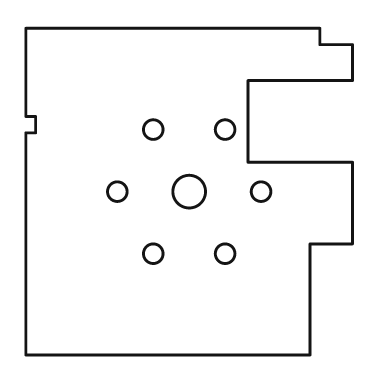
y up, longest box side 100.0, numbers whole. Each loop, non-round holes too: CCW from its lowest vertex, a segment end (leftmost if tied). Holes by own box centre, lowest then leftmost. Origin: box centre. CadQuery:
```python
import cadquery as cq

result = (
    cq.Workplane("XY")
    .moveTo(-50.0, -50.0)
    .lineTo(37.0, -50.0)
    .lineTo(37.0, -16.0)
    .lineTo(50.0, -16.0)
    .lineTo(50.0, 9.0)
    .lineTo(18.0, 9.0)
    .lineTo(18.0, 34.0)
    .lineTo(50.0, 34.0)
    .lineTo(50.0, 45.0)
    .lineTo(40.0, 45.0)
    .lineTo(40.0, 50.0)
    .lineTo(-50.0, 50.0)
    .lineTo(-50.0, 23.0)
    .lineTo(-47.0, 23.0)
    .lineTo(-47.0, 18.0)
    .lineTo(-50.0, 18.0)
    .close()
    .moveTo(-11.0, -19.0)
    .circle(3.0)
    .moveTo(11.0, -19.0)
    .circle(3.0)
    .moveTo(-22.0, 0.0)
    .circle(3.0)
    .moveTo(0.0, 0.0)
    .circle(5.0)
    .moveTo(22.0, 0.0)
    .circle(3.0)
    .moveTo(-11.0, 19.0)
    .circle(3.0)
    .moveTo(11.0, 19.0)
    .circle(3.0)
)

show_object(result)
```